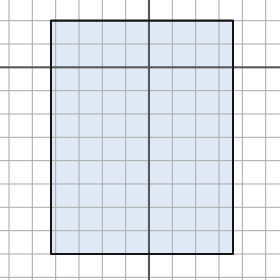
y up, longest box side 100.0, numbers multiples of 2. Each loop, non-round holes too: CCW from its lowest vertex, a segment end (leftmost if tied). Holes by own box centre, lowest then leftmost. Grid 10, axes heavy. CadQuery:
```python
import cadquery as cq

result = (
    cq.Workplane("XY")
    .moveTo(-42.0, -80.0)
    .lineTo(36.0, -80.0)
    .lineTo(36.0, 20.0)
    .lineTo(-42.0, 20.0)
    .close()
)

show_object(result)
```